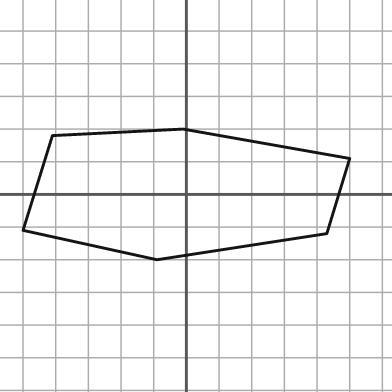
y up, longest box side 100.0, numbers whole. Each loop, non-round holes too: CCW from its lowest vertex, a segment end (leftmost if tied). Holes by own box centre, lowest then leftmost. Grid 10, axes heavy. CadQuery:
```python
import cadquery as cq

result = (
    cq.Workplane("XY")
    .moveTo(-9.0, -20.0)
    .lineTo(43.0, -12.0)
    .lineTo(50.0, 11.0)
    .lineTo(-1.0, 20.0)
    .lineTo(-41.0, 18.0)
    .lineTo(-50.0, -11.0)
    .close()
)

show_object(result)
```